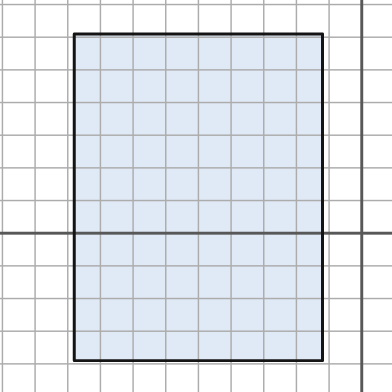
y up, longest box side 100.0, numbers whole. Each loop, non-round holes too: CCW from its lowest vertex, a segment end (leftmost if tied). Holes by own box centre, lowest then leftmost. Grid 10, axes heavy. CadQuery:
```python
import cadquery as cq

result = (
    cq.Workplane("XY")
    .moveTo(-88.0, -39.0)
    .lineTo(-12.0, -39.0)
    .lineTo(-12.0, 61.0)
    .lineTo(-88.0, 61.0)
    .close()
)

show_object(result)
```